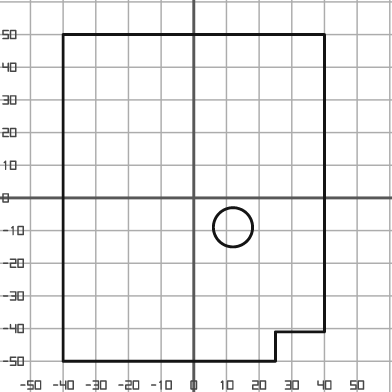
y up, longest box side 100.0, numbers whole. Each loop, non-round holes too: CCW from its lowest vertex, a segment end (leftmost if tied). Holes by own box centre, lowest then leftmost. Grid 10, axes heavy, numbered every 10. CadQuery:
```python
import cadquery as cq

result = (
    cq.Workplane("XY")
    .moveTo(-40.0, -50.0)
    .lineTo(25.0, -50.0)
    .lineTo(25.0, -41.0)
    .lineTo(40.0, -41.0)
    .lineTo(40.0, 50.0)
    .lineTo(-40.0, 50.0)
    .close()
    .moveTo(12.0, -9.0)
    .circle(6.0)
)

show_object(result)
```